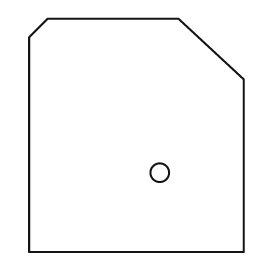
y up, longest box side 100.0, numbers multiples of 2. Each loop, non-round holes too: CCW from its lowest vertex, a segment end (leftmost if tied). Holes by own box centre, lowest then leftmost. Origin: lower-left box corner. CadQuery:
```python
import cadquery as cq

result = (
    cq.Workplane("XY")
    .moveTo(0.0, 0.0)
    .lineTo(92.0, 0.0)
    .lineTo(92.0, 74.0)
    .lineTo(64.0, 100.0)
    .lineTo(8.0, 100.0)
    .lineTo(0.0, 92.0)
    .close()
    .moveTo(56.0, 34.0)
    .circle(4.0)
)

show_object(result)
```